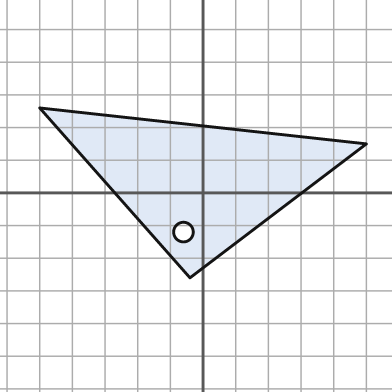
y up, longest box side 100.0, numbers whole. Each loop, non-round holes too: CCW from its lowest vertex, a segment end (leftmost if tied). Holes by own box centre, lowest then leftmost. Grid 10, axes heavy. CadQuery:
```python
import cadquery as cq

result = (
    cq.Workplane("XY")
    .moveTo(-4.0, -26.0)
    .lineTo(50.0, 15.0)
    .lineTo(-50.0, 26.0)
    .close()
    .moveTo(-6.0, -12.0)
    .circle(3.0)
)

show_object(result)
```